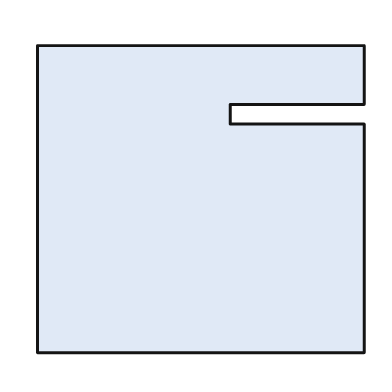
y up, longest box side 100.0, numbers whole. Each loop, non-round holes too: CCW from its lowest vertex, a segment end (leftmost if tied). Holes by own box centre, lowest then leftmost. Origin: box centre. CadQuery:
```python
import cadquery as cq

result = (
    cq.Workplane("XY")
    .moveTo(-50.0, -47.0)
    .lineTo(50.0, -47.0)
    .lineTo(50.0, 23.0)
    .lineTo(9.0, 23.0)
    .lineTo(9.0, 29.0)
    .lineTo(50.0, 29.0)
    .lineTo(50.0, 47.0)
    .lineTo(-50.0, 47.0)
    .close()
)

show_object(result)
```